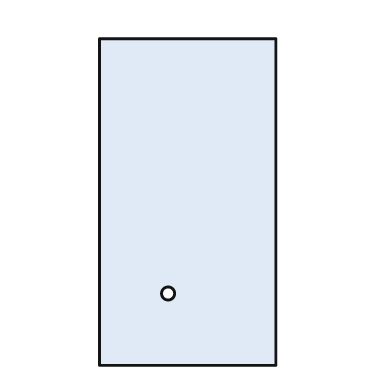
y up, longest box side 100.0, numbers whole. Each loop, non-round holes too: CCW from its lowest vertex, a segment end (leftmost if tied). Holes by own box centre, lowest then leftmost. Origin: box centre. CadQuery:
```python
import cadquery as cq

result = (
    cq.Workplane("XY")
    .moveTo(-27.0, -50.0)
    .lineTo(27.0, -50.0)
    .lineTo(27.0, 50.0)
    .lineTo(-27.0, 50.0)
    .close()
    .moveTo(-6.0, -28.0)
    .circle(2.0)
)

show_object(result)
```